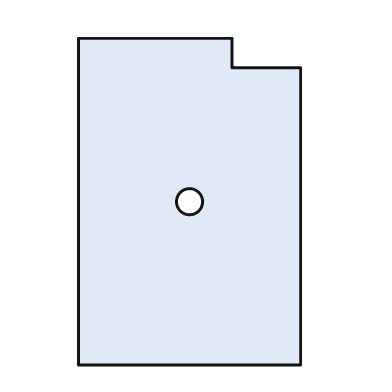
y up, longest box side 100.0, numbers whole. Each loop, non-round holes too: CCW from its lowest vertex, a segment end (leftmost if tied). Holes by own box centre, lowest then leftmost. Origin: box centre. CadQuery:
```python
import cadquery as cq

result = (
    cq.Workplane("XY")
    .moveTo(-34.0, -50.0)
    .lineTo(34.0, -50.0)
    .lineTo(34.0, 41.0)
    .lineTo(13.0, 41.0)
    .lineTo(13.0, 50.0)
    .lineTo(-34.0, 50.0)
    .close()
    .moveTo(0.0, 0.0)
    .circle(4.0)
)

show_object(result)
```